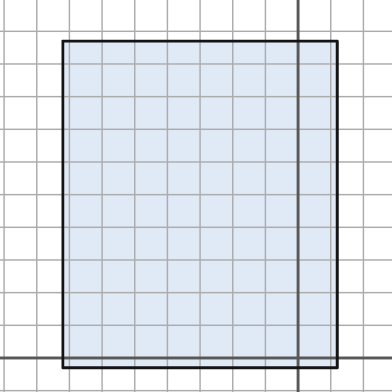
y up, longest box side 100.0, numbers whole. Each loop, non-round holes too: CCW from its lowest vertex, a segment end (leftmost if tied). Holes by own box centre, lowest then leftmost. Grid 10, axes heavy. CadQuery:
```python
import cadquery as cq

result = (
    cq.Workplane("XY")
    .moveTo(-72.0, -3.0)
    .lineTo(12.0, -3.0)
    .lineTo(12.0, 97.0)
    .lineTo(-72.0, 97.0)
    .close()
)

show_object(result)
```